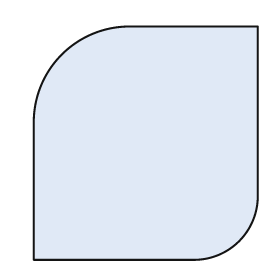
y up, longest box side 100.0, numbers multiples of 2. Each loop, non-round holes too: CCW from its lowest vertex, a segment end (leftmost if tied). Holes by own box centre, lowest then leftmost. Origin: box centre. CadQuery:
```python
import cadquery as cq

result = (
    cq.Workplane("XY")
    .moveTo(-48.0, -50.0)
    .lineTo(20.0, -50.0)
    .threePointArc((40.0, -42.0), (48.0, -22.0))
    .lineTo(48.0, 50.0)
    .lineTo(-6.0, 50.0)
    .threePointArc((-36.0, 38.0), (-48.0, 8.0))
    .close()
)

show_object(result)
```